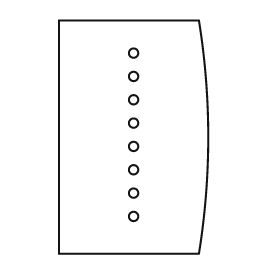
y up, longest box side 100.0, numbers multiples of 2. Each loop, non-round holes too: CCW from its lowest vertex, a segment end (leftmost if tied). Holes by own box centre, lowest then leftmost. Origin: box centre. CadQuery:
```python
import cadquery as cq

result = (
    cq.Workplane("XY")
    .moveTo(-32.0, -50.0)
    .lineTo(28.0, -50.0)
    .threePointArc((32.0, 0.0), (28.0, 50.0))
    .lineTo(-32.0, 50.0)
    .close()
    .moveTo(0.0, -34.0)
    .circle(2.0)
    .moveTo(0.0, -24.0)
    .circle(2.0)
    .moveTo(0.0, -14.0)
    .circle(2.0)
    .moveTo(0.0, -4.0)
    .circle(2.0)
    .moveTo(0.0, 6.0)
    .circle(2.0)
    .moveTo(0.0, 16.0)
    .circle(2.0)
    .moveTo(0.0, 26.0)
    .circle(2.0)
    .moveTo(0.0, 36.0)
    .circle(2.0)
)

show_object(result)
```